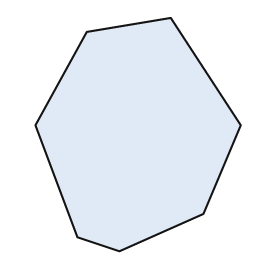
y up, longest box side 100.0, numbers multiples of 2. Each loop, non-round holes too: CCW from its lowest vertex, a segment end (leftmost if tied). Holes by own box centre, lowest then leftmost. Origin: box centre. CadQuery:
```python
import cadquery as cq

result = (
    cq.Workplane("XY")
    .moveTo(-8.0, -50.0)
    .lineTo(28.0, -34.0)
    .lineTo(44.0, 4.0)
    .lineTo(14.0, 50.0)
    .lineTo(-22.0, 44.0)
    .lineTo(-44.0, 4.0)
    .lineTo(-26.0, -44.0)
    .close()
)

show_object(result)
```